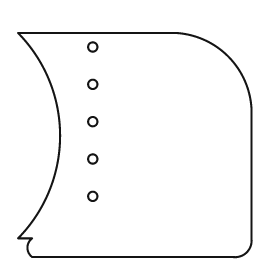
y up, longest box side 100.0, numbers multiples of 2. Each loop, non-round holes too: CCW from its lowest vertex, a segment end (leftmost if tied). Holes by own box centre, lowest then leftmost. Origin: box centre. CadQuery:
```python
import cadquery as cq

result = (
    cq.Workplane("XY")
    .moveTo(-44.0, -48.0)
    .lineTo(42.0, -48.0)
    .threePointArc((48.0, -46.0), (50.0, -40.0))
    .lineTo(50.0, 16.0)
    .threePointArc((40.0, 38.0), (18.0, 48.0))
    .lineTo(-50.0, 48.0)
    .threePointArc((-32.0, 4.0), (-50.0, -40.0))
    .lineTo(-44.0, -40.0)
    .threePointArc((-46.0, -44.0), (-44.0, -48.0))
    .close()
    .moveTo(-18.0, -22.0)
    .circle(2.0)
    .moveTo(-18.0, -6.0)
    .circle(2.0)
    .moveTo(-18.0, 10.0)
    .circle(2.0)
    .moveTo(-18.0, 26.0)
    .circle(2.0)
    .moveTo(-18.0, 42.0)
    .circle(2.0)
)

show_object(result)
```